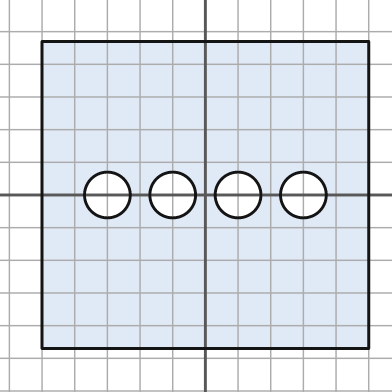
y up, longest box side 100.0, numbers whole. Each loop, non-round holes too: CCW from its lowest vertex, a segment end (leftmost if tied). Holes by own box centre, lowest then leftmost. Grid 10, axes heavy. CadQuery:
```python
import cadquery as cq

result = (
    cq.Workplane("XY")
    .moveTo(-50.0, -47.0)
    .lineTo(50.0, -47.0)
    .lineTo(50.0, 47.0)
    .lineTo(-50.0, 47.0)
    .close()
    .moveTo(-30.0, 0.0)
    .circle(7.0)
    .moveTo(-10.0, 0.0)
    .circle(7.0)
    .moveTo(10.0, 0.0)
    .circle(7.0)
    .moveTo(30.0, 0.0)
    .circle(7.0)
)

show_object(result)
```